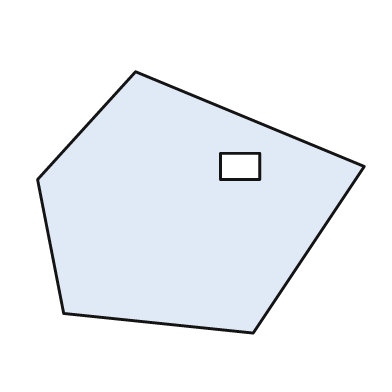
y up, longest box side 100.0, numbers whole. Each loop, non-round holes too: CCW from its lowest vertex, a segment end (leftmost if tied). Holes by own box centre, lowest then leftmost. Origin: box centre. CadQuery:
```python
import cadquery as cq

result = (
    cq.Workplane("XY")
    .moveTo(16.0, -40.0)
    .lineTo(50.0, 11.0)
    .lineTo(-20.0, 40.0)
    .lineTo(-50.0, 7.0)
    .lineTo(-42.0, -34.0)
    .close()
    .moveTo(6.0, 7.0)
    .lineTo(18.0, 7.0)
    .lineTo(18.0, 15.0)
    .lineTo(6.0, 15.0)
    .close()
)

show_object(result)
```